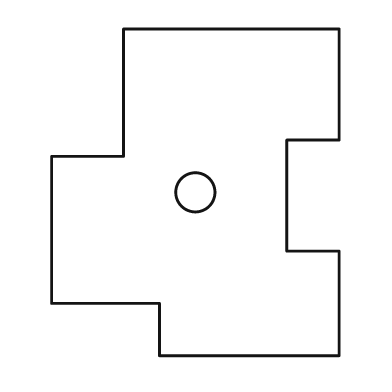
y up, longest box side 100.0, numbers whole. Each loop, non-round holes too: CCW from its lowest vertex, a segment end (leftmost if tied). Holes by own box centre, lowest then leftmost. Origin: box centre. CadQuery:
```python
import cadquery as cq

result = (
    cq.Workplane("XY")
    .moveTo(-11.0, -50.0)
    .lineTo(44.0, -50.0)
    .lineTo(44.0, -18.0)
    .lineTo(28.0, -18.0)
    .lineTo(28.0, 16.0)
    .lineTo(44.0, 16.0)
    .lineTo(44.0, 50.0)
    .lineTo(-22.0, 50.0)
    .lineTo(-22.0, 11.0)
    .lineTo(-44.0, 11.0)
    .lineTo(-44.0, -34.0)
    .lineTo(-11.0, -34.0)
    .close()
    .moveTo(0.0, 0.0)
    .circle(6.0)
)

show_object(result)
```